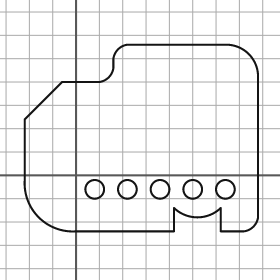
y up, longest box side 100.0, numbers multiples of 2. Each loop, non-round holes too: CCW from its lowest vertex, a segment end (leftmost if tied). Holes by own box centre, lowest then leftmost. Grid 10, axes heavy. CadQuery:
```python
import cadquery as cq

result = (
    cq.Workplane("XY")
    .moveTo(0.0, -24.0)
    .lineTo(42.0, -24.0)
    .lineTo(42.0, -14.0)
    .threePointArc((52.0, -18.0), (62.0, -14.0))
    .lineTo(62.0, -24.0)
    .lineTo(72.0, -24.0)
    .threePointArc((76.0, -22.0), (78.0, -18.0))
    .lineTo(78.0, 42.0)
    .threePointArc((74.0, 52.0), (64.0, 56.0))
    .lineTo(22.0, 56.0)
    .threePointArc((18.0, 54.0), (16.0, 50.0))
    .lineTo(16.0, 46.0)
    .threePointArc((14.0, 42.0), (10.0, 40.0))
    .lineTo(-6.0, 40.0)
    .lineTo(-22.0, 24.0)
    .lineTo(-22.0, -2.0)
    .threePointArc((-16.0, -18.0), (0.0, -24.0))
    .close()
    .moveTo(8.0, -6.0)
    .circle(4.0)
    .moveTo(22.0, -6.0)
    .circle(4.0)
    .moveTo(36.0, -6.0)
    .circle(4.0)
    .moveTo(50.0, -6.0)
    .circle(4.0)
    .moveTo(64.0, -6.0)
    .circle(4.0)
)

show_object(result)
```